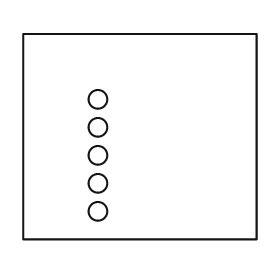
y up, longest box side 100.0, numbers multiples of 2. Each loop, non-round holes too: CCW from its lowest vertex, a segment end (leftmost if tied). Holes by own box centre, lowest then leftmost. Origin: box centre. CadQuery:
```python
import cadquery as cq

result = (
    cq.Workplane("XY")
    .moveTo(-50.0, -44.0)
    .lineTo(50.0, -44.0)
    .lineTo(50.0, 44.0)
    .lineTo(-50.0, 44.0)
    .close()
    .moveTo(-18.0, -32.0)
    .circle(4.0)
    .moveTo(-18.0, -20.0)
    .circle(4.0)
    .moveTo(-18.0, -8.0)
    .circle(4.0)
    .moveTo(-18.0, 4.0)
    .circle(4.0)
    .moveTo(-18.0, 16.0)
    .circle(4.0)
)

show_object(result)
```